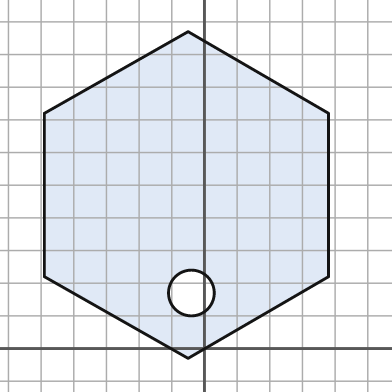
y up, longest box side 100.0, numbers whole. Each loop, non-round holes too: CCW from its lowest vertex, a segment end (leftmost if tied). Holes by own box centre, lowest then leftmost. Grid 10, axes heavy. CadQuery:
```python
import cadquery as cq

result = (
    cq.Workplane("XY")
    .moveTo(-5.0, -3.0)
    .lineTo(38.0, 22.0)
    .lineTo(38.0, 72.0)
    .lineTo(-5.0, 97.0)
    .lineTo(-49.0, 72.0)
    .lineTo(-49.0, 22.0)
    .close()
    .moveTo(-4.0, 17.0)
    .circle(7.0)
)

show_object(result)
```